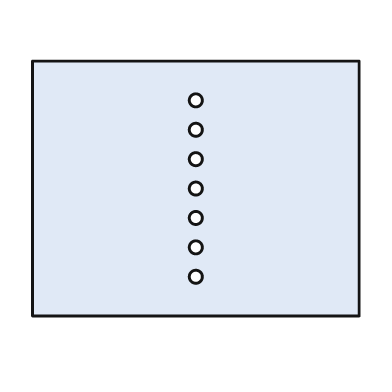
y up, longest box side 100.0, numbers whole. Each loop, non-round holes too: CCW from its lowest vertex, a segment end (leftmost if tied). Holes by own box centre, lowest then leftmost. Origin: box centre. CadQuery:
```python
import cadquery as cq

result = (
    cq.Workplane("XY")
    .moveTo(-50.0, -39.0)
    .lineTo(50.0, -39.0)
    .lineTo(50.0, 39.0)
    .lineTo(-50.0, 39.0)
    .close()
    .moveTo(0.0, -27.0)
    .circle(2.0)
    .moveTo(0.0, -18.0)
    .circle(2.0)
    .moveTo(0.0, -9.0)
    .circle(2.0)
    .moveTo(0.0, 0.0)
    .circle(2.0)
    .moveTo(0.0, 9.0)
    .circle(2.0)
    .moveTo(0.0, 18.0)
    .circle(2.0)
    .moveTo(0.0, 27.0)
    .circle(2.0)
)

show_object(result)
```